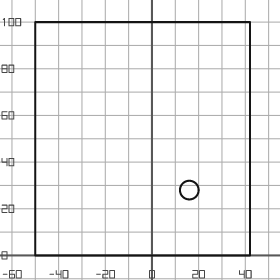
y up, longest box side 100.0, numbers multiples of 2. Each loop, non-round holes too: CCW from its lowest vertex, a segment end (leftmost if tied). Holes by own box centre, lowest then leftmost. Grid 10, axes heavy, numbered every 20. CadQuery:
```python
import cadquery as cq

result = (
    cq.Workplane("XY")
    .moveTo(-50.0, 0.0)
    .lineTo(42.0, 0.0)
    .lineTo(42.0, 100.0)
    .lineTo(-50.0, 100.0)
    .close()
    .moveTo(16.0, 28.0)
    .circle(4.0)
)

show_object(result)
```